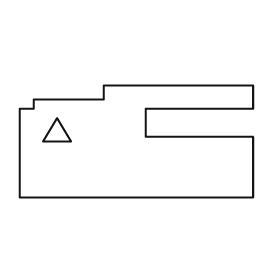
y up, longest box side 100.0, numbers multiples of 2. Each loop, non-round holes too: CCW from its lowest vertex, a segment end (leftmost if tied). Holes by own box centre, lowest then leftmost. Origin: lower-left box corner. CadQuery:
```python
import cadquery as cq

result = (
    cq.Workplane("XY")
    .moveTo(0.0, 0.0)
    .lineTo(100.0, 0.0)
    .lineTo(100.0, 26.0)
    .lineTo(54.0, 26.0)
    .lineTo(54.0, 38.0)
    .lineTo(100.0, 38.0)
    .lineTo(100.0, 48.0)
    .lineTo(36.0, 48.0)
    .lineTo(36.0, 42.0)
    .lineTo(6.0, 42.0)
    .lineTo(6.0, 38.0)
    .lineTo(0.0, 38.0)
    .close()
    .moveTo(10.0, 24.0)
    .lineTo(22.0, 24.0)
    .lineTo(16.0, 34.0)
    .close()
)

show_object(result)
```